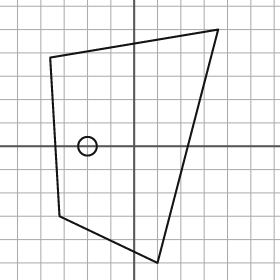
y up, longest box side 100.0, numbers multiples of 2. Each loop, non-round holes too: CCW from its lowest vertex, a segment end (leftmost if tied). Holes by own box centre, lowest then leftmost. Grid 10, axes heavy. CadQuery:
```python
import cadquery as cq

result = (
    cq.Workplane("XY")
    .moveTo(10.0, -50.0)
    .lineTo(36.0, 50.0)
    .lineTo(-36.0, 38.0)
    .lineTo(-32.0, -30.0)
    .close()
    .moveTo(-20.0, 0.0)
    .circle(4.0)
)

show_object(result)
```